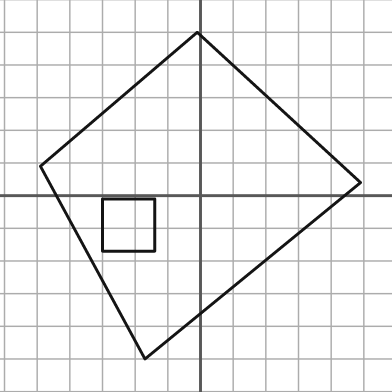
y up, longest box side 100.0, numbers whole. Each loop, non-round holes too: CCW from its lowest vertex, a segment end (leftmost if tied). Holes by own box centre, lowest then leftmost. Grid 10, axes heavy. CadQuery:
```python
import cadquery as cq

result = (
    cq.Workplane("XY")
    .moveTo(-17.0, -50.0)
    .lineTo(49.0, 4.0)
    .lineTo(-1.0, 50.0)
    .lineTo(-49.0, 9.0)
    .close()
    .moveTo(-30.0, -17.0)
    .lineTo(-14.0, -17.0)
    .lineTo(-14.0, -1.0)
    .lineTo(-30.0, -1.0)
    .close()
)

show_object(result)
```